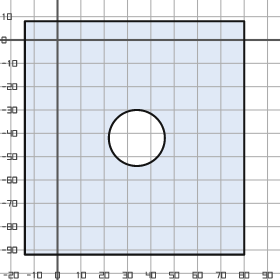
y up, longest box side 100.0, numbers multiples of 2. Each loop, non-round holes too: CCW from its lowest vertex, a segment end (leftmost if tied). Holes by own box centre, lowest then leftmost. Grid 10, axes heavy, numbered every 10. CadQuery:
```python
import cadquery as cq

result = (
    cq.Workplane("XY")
    .moveTo(-14.0, -92.0)
    .lineTo(80.0, -92.0)
    .lineTo(80.0, 8.0)
    .lineTo(-14.0, 8.0)
    .close()
    .moveTo(34.0, -42.0)
    .circle(12.0)
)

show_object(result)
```